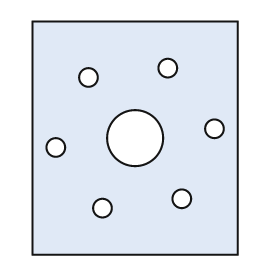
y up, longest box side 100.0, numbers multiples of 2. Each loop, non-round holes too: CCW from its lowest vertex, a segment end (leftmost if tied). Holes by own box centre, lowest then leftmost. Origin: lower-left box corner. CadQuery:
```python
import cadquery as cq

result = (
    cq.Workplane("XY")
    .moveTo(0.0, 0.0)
    .lineTo(88.0, 0.0)
    .lineTo(88.0, 100.0)
    .lineTo(0.0, 100.0)
    .close()
    .moveTo(30.0, 20.0)
    .circle(4.0)
    .moveTo(64.0, 24.0)
    .circle(4.0)
    .moveTo(10.0, 46.0)
    .circle(4.0)
    .moveTo(44.0, 50.0)
    .circle(12.0)
    .moveTo(78.0, 54.0)
    .circle(4.0)
    .moveTo(24.0, 76.0)
    .circle(4.0)
    .moveTo(58.0, 80.0)
    .circle(4.0)
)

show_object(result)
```